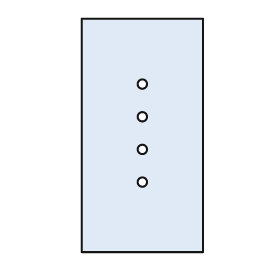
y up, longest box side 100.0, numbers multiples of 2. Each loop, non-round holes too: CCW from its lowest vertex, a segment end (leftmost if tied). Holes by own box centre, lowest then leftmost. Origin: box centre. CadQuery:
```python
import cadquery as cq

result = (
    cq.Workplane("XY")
    .moveTo(-26.0, -50.0)
    .lineTo(26.0, -50.0)
    .lineTo(26.0, 50.0)
    .lineTo(-26.0, 50.0)
    .close()
    .moveTo(0.0, -20.0)
    .circle(2.0)
    .moveTo(0.0, -6.0)
    .circle(2.0)
    .moveTo(0.0, 8.0)
    .circle(2.0)
    .moveTo(0.0, 22.0)
    .circle(2.0)
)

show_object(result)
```